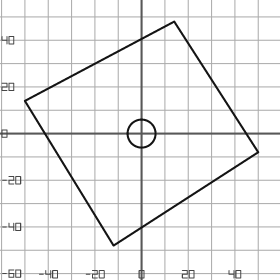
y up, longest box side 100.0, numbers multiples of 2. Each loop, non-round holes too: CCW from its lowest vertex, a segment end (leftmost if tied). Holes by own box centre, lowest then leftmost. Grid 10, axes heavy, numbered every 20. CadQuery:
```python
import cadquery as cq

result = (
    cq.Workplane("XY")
    .moveTo(-12.0, -48.0)
    .lineTo(50.0, -8.0)
    .lineTo(14.0, 48.0)
    .lineTo(-50.0, 14.0)
    .close()
    .moveTo(0.0, 0.0)
    .circle(6.0)
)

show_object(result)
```